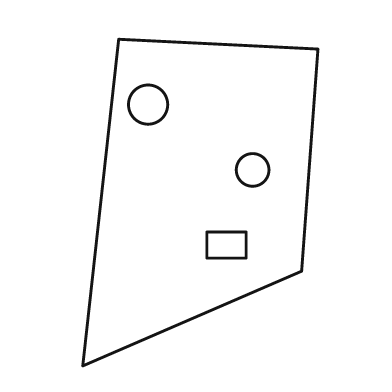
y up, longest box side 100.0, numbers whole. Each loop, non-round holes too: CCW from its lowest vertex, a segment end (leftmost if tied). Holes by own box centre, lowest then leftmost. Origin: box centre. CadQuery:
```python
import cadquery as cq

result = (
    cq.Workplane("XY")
    .moveTo(-36.0, -50.0)
    .lineTo(31.0, -21.0)
    .lineTo(36.0, 47.0)
    .lineTo(-25.0, 50.0)
    .close()
    .moveTo(2.0, -17.0)
    .lineTo(14.0, -17.0)
    .lineTo(14.0, -9.0)
    .lineTo(2.0, -9.0)
    .close()
    .moveTo(16.0, 10.0)
    .circle(5.0)
    .moveTo(-16.0, 30.0)
    .circle(6.0)
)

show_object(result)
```